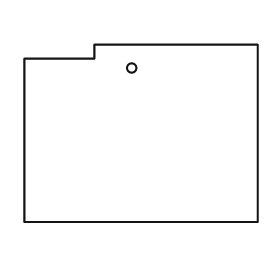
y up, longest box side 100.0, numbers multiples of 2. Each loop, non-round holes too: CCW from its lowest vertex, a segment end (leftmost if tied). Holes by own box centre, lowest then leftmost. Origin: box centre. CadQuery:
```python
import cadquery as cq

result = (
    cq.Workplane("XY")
    .moveTo(-50.0, -38.0)
    .lineTo(50.0, -38.0)
    .lineTo(50.0, 38.0)
    .lineTo(-20.0, 38.0)
    .lineTo(-20.0, 32.0)
    .lineTo(-50.0, 32.0)
    .close()
    .moveTo(-4.0, 28.0)
    .circle(2.0)
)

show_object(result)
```